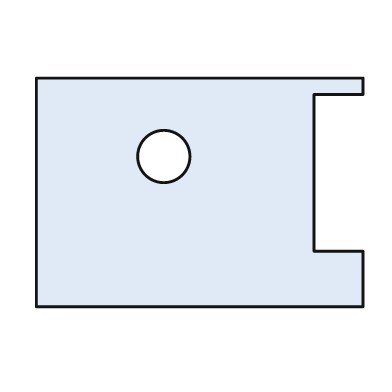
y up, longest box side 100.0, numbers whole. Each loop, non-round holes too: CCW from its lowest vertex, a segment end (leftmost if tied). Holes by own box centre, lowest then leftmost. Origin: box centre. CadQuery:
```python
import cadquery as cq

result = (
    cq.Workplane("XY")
    .moveTo(-50.0, -35.0)
    .lineTo(50.0, -35.0)
    .lineTo(50.0, -18.0)
    .lineTo(35.0, -18.0)
    .lineTo(35.0, 30.0)
    .lineTo(50.0, 30.0)
    .lineTo(50.0, 35.0)
    .lineTo(-50.0, 35.0)
    .close()
    .moveTo(-11.0, 11.0)
    .circle(8.0)
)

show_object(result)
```